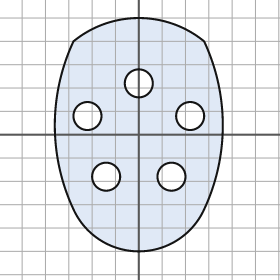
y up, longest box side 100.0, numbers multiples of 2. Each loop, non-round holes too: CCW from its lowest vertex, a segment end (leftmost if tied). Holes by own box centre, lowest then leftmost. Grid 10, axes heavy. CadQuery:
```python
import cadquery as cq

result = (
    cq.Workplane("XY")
    .moveTo(-28.0, -32.0)
    .threePointArc((0.0, -50.0), (28.0, -32.0))
    .threePointArc((36.0, 4.0), (28.0, 40.0))
    .threePointArc((0.0, 50.0), (-28.0, 40.0))
    .threePointArc((-36.0, 4.0), (-28.0, -32.0))
    .close()
    .moveTo(-14.0, -18.0)
    .circle(6.0)
    .moveTo(14.0, -18.0)
    .circle(6.0)
    .moveTo(-22.0, 8.0)
    .circle(6.0)
    .moveTo(22.0, 8.0)
    .circle(6.0)
    .moveTo(0.0, 22.0)
    .circle(6.0)
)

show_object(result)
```